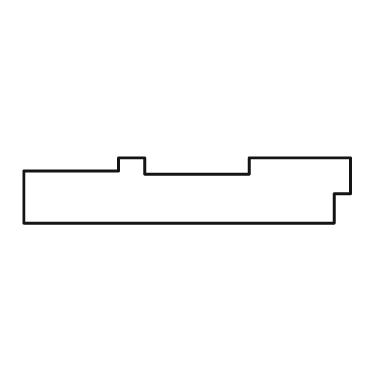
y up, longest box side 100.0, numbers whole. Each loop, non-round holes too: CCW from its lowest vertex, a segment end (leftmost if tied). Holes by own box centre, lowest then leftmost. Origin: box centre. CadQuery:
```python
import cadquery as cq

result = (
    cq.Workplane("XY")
    .moveTo(-50.0, -10.0)
    .lineTo(45.0, -10.0)
    .lineTo(45.0, -1.0)
    .lineTo(50.0, -1.0)
    .lineTo(50.0, 10.0)
    .lineTo(19.0, 10.0)
    .lineTo(19.0, 5.0)
    .lineTo(-13.0, 5.0)
    .lineTo(-13.0, 10.0)
    .lineTo(-21.0, 10.0)
    .lineTo(-21.0, 6.0)
    .lineTo(-50.0, 6.0)
    .close()
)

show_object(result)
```